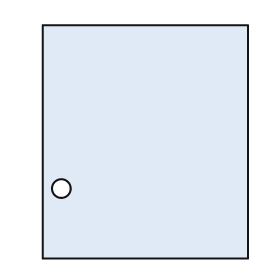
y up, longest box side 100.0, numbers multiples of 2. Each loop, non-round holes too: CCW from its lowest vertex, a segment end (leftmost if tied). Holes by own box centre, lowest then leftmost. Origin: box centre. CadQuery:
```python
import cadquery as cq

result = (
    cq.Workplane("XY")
    .moveTo(-44.0, -50.0)
    .lineTo(44.0, -50.0)
    .lineTo(44.0, 50.0)
    .lineTo(-44.0, 50.0)
    .close()
    .moveTo(-36.0, -20.0)
    .circle(4.0)
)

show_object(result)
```